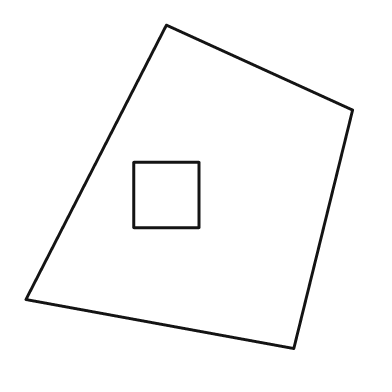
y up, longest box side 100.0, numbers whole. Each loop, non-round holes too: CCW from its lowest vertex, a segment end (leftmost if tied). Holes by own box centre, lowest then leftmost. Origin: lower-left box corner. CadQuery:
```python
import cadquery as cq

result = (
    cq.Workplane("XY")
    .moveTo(82.0, 0.0)
    .lineTo(100.0, 73.0)
    .lineTo(43.0, 99.0)
    .lineTo(0.0, 15.0)
    .close()
    .moveTo(33.0, 37.0)
    .lineTo(53.0, 37.0)
    .lineTo(53.0, 57.0)
    .lineTo(33.0, 57.0)
    .close()
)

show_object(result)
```